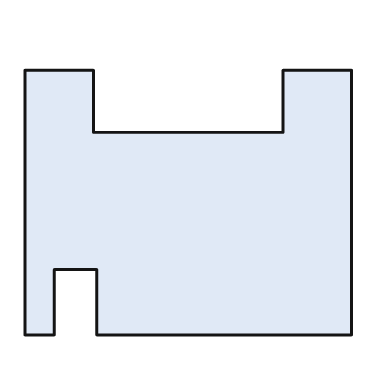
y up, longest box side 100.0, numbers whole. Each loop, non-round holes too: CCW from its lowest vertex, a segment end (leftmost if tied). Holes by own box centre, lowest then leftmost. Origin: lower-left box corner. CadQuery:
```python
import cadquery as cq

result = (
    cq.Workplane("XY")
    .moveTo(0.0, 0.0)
    .lineTo(9.0, 0.0)
    .lineTo(9.0, 20.0)
    .lineTo(22.0, 20.0)
    .lineTo(22.0, 0.0)
    .lineTo(100.0, 0.0)
    .lineTo(100.0, 81.0)
    .lineTo(79.0, 81.0)
    .lineTo(79.0, 62.0)
    .lineTo(21.0, 62.0)
    .lineTo(21.0, 81.0)
    .lineTo(0.0, 81.0)
    .close()
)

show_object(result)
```